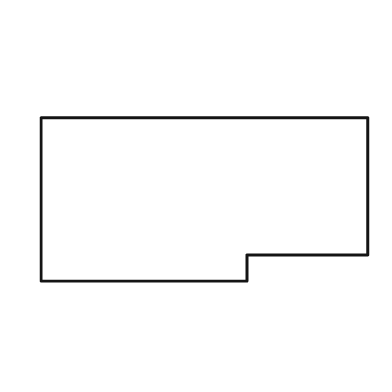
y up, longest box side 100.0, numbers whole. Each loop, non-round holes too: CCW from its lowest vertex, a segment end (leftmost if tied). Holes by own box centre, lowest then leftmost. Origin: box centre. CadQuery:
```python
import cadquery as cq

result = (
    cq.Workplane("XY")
    .moveTo(-50.0, -25.0)
    .lineTo(13.0, -25.0)
    .lineTo(13.0, -17.0)
    .lineTo(50.0, -17.0)
    .lineTo(50.0, 25.0)
    .lineTo(-50.0, 25.0)
    .close()
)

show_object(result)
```